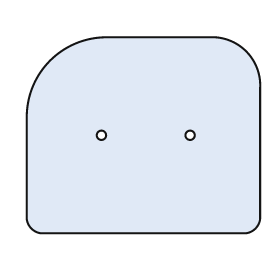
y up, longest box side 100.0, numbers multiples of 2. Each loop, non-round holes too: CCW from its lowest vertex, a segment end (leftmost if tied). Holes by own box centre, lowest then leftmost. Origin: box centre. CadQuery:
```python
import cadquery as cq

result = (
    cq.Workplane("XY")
    .moveTo(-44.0, -42.0)
    .lineTo(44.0, -42.0)
    .threePointArc((48.0, -40.0), (50.0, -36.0))
    .lineTo(50.0, 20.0)
    .threePointArc((44.0, 36.0), (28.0, 42.0))
    .lineTo(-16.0, 42.0)
    .threePointArc((-40.0, 32.0), (-50.0, 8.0))
    .lineTo(-50.0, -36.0)
    .threePointArc((-48.0, -40.0), (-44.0, -42.0))
    .close()
    .moveTo(-18.0, 0.0)
    .circle(2.0)
    .moveTo(20.0, 0.0)
    .circle(2.0)
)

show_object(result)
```